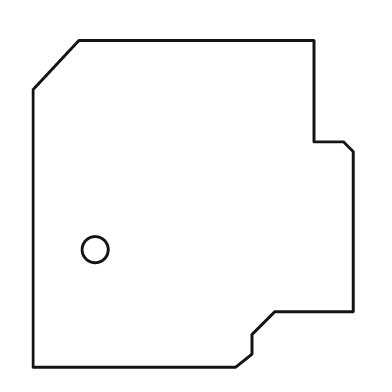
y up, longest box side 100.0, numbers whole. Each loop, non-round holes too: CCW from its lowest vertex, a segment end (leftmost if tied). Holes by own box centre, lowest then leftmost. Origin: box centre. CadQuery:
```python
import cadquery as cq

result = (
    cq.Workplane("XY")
    .moveTo(-49.0, -50.0)
    .lineTo(13.0, -50.0)
    .lineTo(18.0, -46.0)
    .lineTo(18.0, -40.0)
    .lineTo(25.0, -33.0)
    .lineTo(49.0, -33.0)
    .lineTo(49.0, 16.0)
    .lineTo(46.0, 19.0)
    .lineTo(37.0, 19.0)
    .lineTo(37.0, 50.0)
    .lineTo(-35.0, 50.0)
    .lineTo(-49.0, 35.0)
    .close()
    .moveTo(-30.0, -14.0)
    .circle(4.0)
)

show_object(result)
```